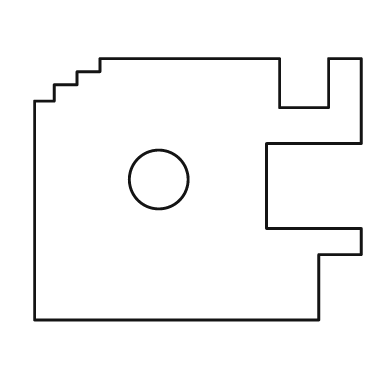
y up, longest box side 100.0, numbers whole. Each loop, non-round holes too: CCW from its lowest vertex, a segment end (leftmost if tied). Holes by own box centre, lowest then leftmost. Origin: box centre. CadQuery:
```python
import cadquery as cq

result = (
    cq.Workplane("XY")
    .moveTo(-50.0, -40.0)
    .lineTo(37.0, -40.0)
    .lineTo(37.0, -20.0)
    .lineTo(50.0, -20.0)
    .lineTo(50.0, -12.0)
    .lineTo(21.0, -12.0)
    .lineTo(21.0, 14.0)
    .lineTo(50.0, 14.0)
    .lineTo(50.0, 40.0)
    .lineTo(40.0, 40.0)
    .lineTo(40.0, 25.0)
    .lineTo(25.0, 25.0)
    .lineTo(25.0, 40.0)
    .lineTo(-30.0, 40.0)
    .lineTo(-30.0, 36.0)
    .lineTo(-37.0, 36.0)
    .lineTo(-37.0, 32.0)
    .lineTo(-44.0, 32.0)
    .lineTo(-44.0, 27.0)
    .lineTo(-50.0, 27.0)
    .close()
    .moveTo(-12.0, 3.0)
    .circle(9.0)
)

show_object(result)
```